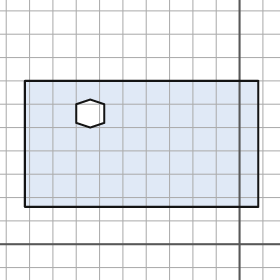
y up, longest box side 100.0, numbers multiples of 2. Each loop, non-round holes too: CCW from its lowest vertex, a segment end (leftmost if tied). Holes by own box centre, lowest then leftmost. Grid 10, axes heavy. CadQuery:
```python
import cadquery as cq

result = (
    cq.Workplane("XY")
    .moveTo(-92.0, 16.0)
    .lineTo(8.0, 16.0)
    .lineTo(8.0, 70.0)
    .lineTo(-92.0, 70.0)
    .close()
    .moveTo(-64.0, 50.0)
    .lineTo(-58.0, 52.0)
    .lineTo(-58.0, 60.0)
    .lineTo(-64.0, 62.0)
    .lineTo(-70.0, 60.0)
    .lineTo(-70.0, 52.0)
    .close()
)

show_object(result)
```